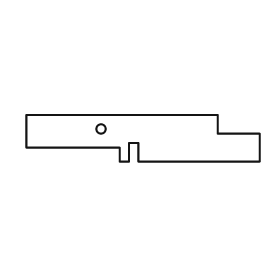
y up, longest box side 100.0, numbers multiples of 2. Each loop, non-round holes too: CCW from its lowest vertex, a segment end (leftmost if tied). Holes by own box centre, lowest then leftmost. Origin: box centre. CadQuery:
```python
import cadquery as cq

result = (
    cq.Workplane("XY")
    .moveTo(-10.0, -10.0)
    .lineTo(-6.0, -10.0)
    .lineTo(-6.0, -2.0)
    .lineTo(-2.0, -2.0)
    .lineTo(-2.0, -10.0)
    .lineTo(50.0, -10.0)
    .lineTo(50.0, 2.0)
    .lineTo(32.0, 2.0)
    .lineTo(32.0, 10.0)
    .lineTo(-50.0, 10.0)
    .lineTo(-50.0, -4.0)
    .lineTo(-10.0, -4.0)
    .close()
    .moveTo(-18.0, 4.0)
    .circle(2.0)
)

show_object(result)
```